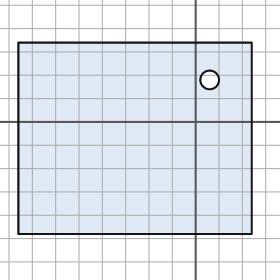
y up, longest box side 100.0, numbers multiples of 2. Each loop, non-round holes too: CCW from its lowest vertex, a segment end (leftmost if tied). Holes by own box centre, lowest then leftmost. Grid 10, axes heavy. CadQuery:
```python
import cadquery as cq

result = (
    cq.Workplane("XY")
    .moveTo(-76.0, -48.0)
    .lineTo(24.0, -48.0)
    .lineTo(24.0, 34.0)
    .lineTo(-76.0, 34.0)
    .close()
    .moveTo(6.0, 18.0)
    .circle(4.0)
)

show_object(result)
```